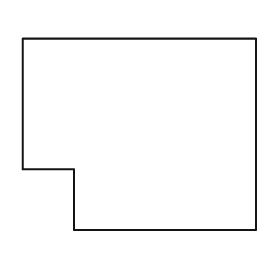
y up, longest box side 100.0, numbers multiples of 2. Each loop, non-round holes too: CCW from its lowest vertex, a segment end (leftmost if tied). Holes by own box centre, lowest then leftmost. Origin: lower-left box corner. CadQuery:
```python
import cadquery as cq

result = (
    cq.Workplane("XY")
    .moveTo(22.0, 0.0)
    .lineTo(100.0, 0.0)
    .lineTo(100.0, 82.0)
    .lineTo(0.0, 82.0)
    .lineTo(0.0, 26.0)
    .lineTo(22.0, 26.0)
    .close()
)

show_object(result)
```